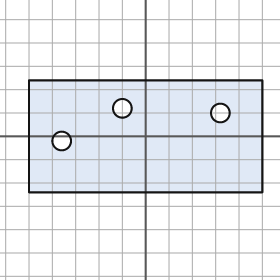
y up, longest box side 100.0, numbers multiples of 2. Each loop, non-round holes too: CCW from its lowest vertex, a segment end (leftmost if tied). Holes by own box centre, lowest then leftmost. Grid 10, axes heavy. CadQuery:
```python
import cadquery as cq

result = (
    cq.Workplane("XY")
    .moveTo(-50.0, -24.0)
    .lineTo(50.0, -24.0)
    .lineTo(50.0, 24.0)
    .lineTo(-50.0, 24.0)
    .close()
    .moveTo(-36.0, -2.0)
    .circle(4.0)
    .moveTo(32.0, 10.0)
    .circle(4.0)
    .moveTo(-10.0, 12.0)
    .circle(4.0)
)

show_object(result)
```